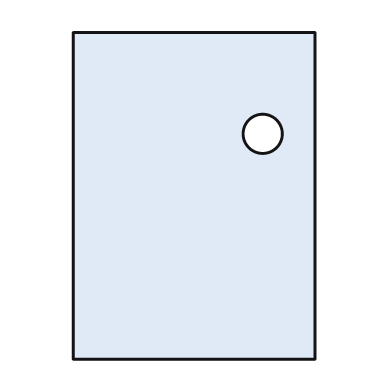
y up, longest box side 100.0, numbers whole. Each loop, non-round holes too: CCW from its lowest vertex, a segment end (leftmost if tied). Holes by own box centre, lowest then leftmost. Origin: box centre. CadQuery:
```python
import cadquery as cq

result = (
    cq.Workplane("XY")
    .moveTo(-37.0, -50.0)
    .lineTo(37.0, -50.0)
    .lineTo(37.0, 50.0)
    .lineTo(-37.0, 50.0)
    .close()
    .moveTo(21.0, 19.0)
    .circle(6.0)
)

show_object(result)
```